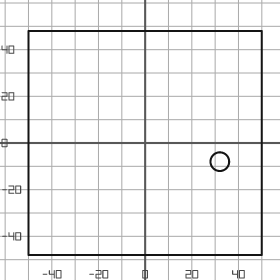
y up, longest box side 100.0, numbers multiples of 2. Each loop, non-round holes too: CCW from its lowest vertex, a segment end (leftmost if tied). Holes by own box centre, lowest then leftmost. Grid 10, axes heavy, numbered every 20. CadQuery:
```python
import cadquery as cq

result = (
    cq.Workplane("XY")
    .moveTo(-50.0, -48.0)
    .lineTo(50.0, -48.0)
    .lineTo(50.0, 48.0)
    .lineTo(-50.0, 48.0)
    .close()
    .moveTo(32.0, -8.0)
    .circle(4.0)
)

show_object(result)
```